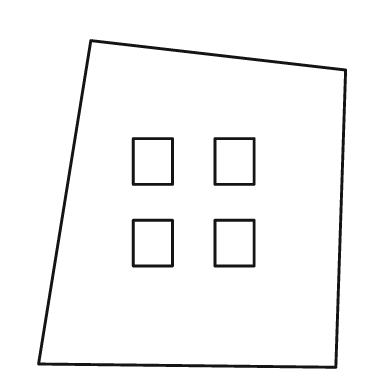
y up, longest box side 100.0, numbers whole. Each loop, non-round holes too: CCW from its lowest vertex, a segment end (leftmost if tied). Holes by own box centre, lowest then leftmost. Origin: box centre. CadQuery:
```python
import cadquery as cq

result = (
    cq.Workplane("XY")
    .moveTo(44.0, -50.0)
    .lineTo(47.0, 41.0)
    .lineTo(-31.0, 50.0)
    .lineTo(-47.0, -49.0)
    .close()
    .moveTo(-18.0, -19.0)
    .lineTo(-6.0, -19.0)
    .lineTo(-6.0, -5.0)
    .lineTo(-18.0, -5.0)
    .close()
    .moveTo(7.0, -19.0)
    .lineTo(19.0, -19.0)
    .lineTo(19.0, -5.0)
    .lineTo(7.0, -5.0)
    .close()
    .moveTo(-18.0, 6.0)
    .lineTo(-6.0, 6.0)
    .lineTo(-6.0, 20.0)
    .lineTo(-18.0, 20.0)
    .close()
    .moveTo(7.0, 6.0)
    .lineTo(19.0, 6.0)
    .lineTo(19.0, 20.0)
    .lineTo(7.0, 20.0)
    .close()
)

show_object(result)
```